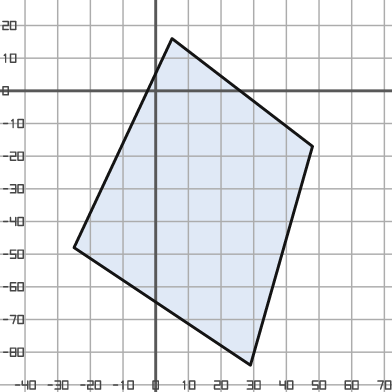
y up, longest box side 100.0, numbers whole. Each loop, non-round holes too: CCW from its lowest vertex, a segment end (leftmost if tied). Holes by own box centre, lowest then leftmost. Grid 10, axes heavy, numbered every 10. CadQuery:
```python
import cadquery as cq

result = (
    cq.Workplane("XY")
    .moveTo(29.0, -84.0)
    .lineTo(48.0, -17.0)
    .lineTo(5.0, 16.0)
    .lineTo(-25.0, -48.0)
    .close()
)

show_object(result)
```